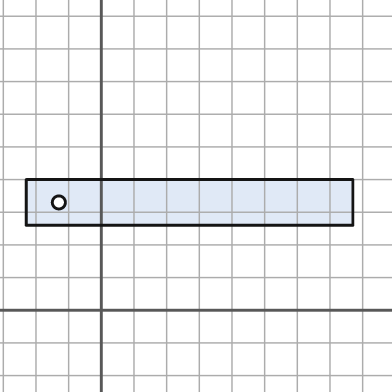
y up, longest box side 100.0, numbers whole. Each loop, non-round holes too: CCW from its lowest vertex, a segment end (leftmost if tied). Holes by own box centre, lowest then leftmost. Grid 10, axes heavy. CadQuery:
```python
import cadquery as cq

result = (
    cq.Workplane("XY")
    .moveTo(-23.0, 26.0)
    .lineTo(77.0, 26.0)
    .lineTo(77.0, 40.0)
    .lineTo(-23.0, 40.0)
    .close()
    .moveTo(-13.0, 33.0)
    .circle(2.0)
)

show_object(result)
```